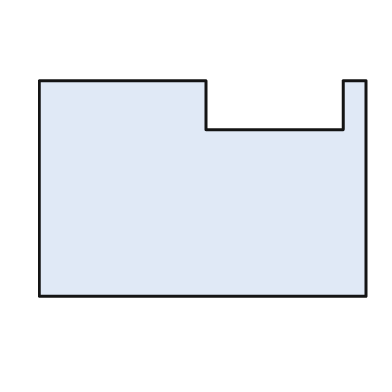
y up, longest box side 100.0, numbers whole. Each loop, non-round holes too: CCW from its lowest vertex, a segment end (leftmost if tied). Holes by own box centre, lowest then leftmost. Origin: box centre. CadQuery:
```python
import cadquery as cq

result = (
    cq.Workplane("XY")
    .moveTo(-50.0, -33.0)
    .lineTo(50.0, -33.0)
    .lineTo(50.0, 33.0)
    .lineTo(43.0, 33.0)
    .lineTo(43.0, 18.0)
    .lineTo(1.0, 18.0)
    .lineTo(1.0, 33.0)
    .lineTo(-50.0, 33.0)
    .close()
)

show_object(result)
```